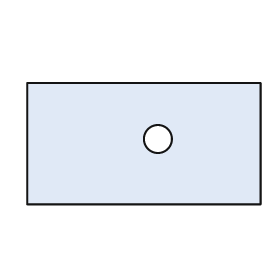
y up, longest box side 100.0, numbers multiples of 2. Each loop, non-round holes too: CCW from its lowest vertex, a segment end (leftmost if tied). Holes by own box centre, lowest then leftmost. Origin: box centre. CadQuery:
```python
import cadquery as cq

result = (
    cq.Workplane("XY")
    .moveTo(-50.0, -26.0)
    .lineTo(50.0, -26.0)
    .lineTo(50.0, 26.0)
    .lineTo(-50.0, 26.0)
    .close()
    .moveTo(6.0, 2.0)
    .circle(6.0)
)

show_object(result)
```